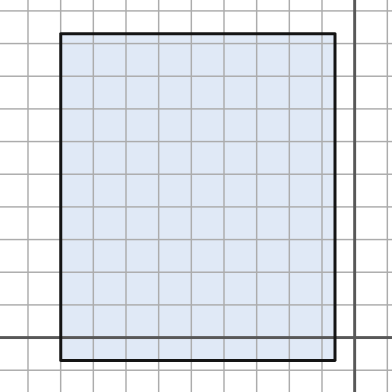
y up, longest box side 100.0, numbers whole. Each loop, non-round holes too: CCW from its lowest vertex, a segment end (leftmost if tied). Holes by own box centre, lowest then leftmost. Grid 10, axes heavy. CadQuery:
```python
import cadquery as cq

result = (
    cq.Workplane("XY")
    .moveTo(-90.0, -7.0)
    .lineTo(-6.0, -7.0)
    .lineTo(-6.0, 93.0)
    .lineTo(-90.0, 93.0)
    .close()
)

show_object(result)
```